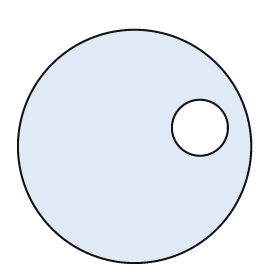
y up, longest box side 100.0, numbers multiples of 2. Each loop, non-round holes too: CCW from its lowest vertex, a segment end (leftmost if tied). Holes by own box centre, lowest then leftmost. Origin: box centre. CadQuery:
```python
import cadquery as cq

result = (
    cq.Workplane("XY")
    .moveTo(0.0, 0.0)
    .circle(50.0)
    .moveTo(28.0, 8.0)
    .circle(12.0)
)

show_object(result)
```